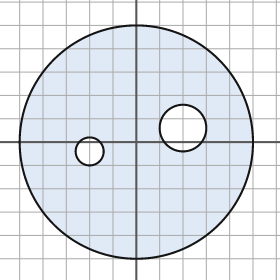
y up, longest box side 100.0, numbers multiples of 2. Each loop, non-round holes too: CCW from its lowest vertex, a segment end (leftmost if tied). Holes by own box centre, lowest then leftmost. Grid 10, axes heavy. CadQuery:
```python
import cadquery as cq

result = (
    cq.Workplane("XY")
    .moveTo(0.0, 0.0)
    .circle(50.0)
    .moveTo(-20.0, -4.0)
    .circle(6.0)
    .moveTo(20.0, 6.0)
    .circle(10.0)
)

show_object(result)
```